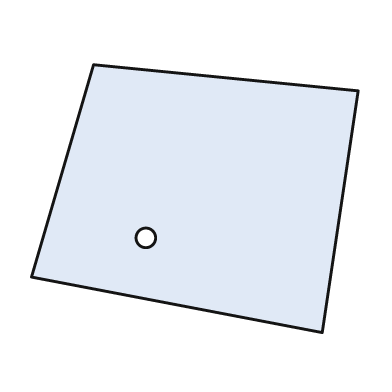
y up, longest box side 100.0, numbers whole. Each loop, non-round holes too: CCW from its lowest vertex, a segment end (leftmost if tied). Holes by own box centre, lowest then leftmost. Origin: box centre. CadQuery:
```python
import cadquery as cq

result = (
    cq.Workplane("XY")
    .moveTo(39.0, -41.0)
    .lineTo(50.0, 33.0)
    .lineTo(-31.0, 41.0)
    .lineTo(-50.0, -24.0)
    .close()
    .moveTo(-15.0, -12.0)
    .circle(3.0)
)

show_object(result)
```